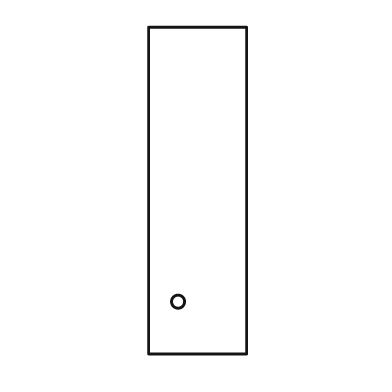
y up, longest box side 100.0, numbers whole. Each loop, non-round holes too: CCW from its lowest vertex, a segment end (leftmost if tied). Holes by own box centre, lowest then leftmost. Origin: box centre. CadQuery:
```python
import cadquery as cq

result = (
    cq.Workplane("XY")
    .moveTo(-15.0, -50.0)
    .lineTo(15.0, -50.0)
    .lineTo(15.0, 50.0)
    .lineTo(-15.0, 50.0)
    .close()
    .moveTo(-6.0, -34.0)
    .circle(2.0)
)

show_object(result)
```